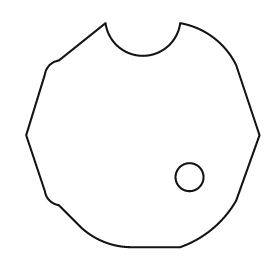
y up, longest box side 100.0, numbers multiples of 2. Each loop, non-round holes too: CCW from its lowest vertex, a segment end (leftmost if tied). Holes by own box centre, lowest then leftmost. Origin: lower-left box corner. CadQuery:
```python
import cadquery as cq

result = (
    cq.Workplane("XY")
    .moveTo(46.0, 0.0)
    .lineTo(66.0, 0.0)
    .threePointArc((80.0, 8.0), (90.0, 20.0))
    .lineTo(100.0, 48.0)
    .lineTo(90.0, 78.0)
    .threePointArc((80.0, 90.0), (66.0, 96.0))
    .threePointArc((50.0, 82.0), (34.0, 96.0))
    .lineTo(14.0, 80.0)
    .threePointArc((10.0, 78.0), (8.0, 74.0))
    .lineTo(0.0, 48.0)
    .lineTo(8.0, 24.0)
    .threePointArc((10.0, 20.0), (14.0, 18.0))
    .lineTo(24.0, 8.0)
    .threePointArc((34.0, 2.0), (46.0, 0.0))
    .close()
    .moveTo(70.0, 30.0)
    .circle(6.0)
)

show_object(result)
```